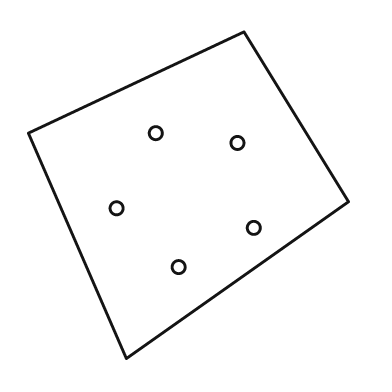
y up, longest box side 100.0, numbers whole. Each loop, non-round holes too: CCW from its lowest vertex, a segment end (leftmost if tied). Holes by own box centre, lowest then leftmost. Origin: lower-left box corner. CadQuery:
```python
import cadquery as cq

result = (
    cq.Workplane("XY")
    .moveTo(30.0, 0.0)
    .lineTo(98.0, 48.0)
    .lineTo(66.0, 100.0)
    .lineTo(0.0, 69.0)
    .close()
    .moveTo(46.0, 28.0)
    .circle(2.0)
    .moveTo(69.0, 40.0)
    .circle(2.0)
    .moveTo(27.0, 46.0)
    .circle(2.0)
    .moveTo(64.0, 66.0)
    .circle(2.0)
    .moveTo(39.0, 69.0)
    .circle(2.0)
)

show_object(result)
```